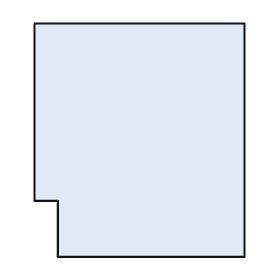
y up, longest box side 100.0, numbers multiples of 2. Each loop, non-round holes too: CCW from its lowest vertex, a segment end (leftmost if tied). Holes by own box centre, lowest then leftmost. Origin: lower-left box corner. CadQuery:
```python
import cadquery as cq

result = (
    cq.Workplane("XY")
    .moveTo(10.0, 0.0)
    .lineTo(90.0, 0.0)
    .lineTo(90.0, 100.0)
    .lineTo(0.0, 100.0)
    .lineTo(0.0, 24.0)
    .lineTo(10.0, 24.0)
    .close()
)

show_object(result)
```